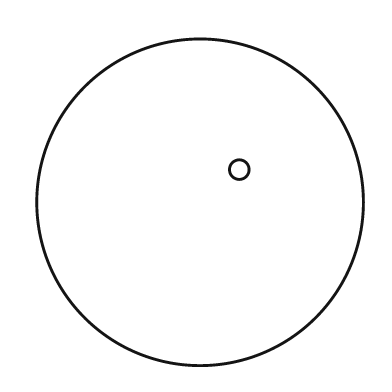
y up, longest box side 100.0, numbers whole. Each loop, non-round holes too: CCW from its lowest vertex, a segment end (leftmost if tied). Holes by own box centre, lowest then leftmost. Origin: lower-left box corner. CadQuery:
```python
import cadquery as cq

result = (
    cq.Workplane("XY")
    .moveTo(50.0, 50.0)
    .circle(50.0)
    .moveTo(62.0, 60.0)
    .circle(3.0)
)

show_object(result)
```